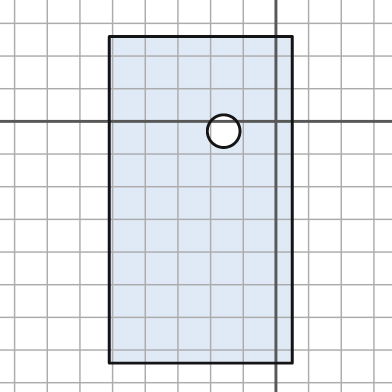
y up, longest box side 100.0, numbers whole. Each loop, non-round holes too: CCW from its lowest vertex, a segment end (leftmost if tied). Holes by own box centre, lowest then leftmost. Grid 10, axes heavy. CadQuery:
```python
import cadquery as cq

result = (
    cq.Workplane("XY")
    .moveTo(-51.0, -74.0)
    .lineTo(5.0, -74.0)
    .lineTo(5.0, 26.0)
    .lineTo(-51.0, 26.0)
    .close()
    .moveTo(-16.0, -3.0)
    .circle(5.0)
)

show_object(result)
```